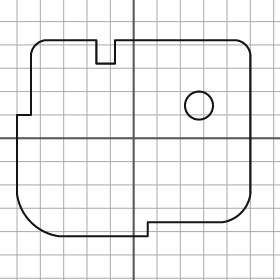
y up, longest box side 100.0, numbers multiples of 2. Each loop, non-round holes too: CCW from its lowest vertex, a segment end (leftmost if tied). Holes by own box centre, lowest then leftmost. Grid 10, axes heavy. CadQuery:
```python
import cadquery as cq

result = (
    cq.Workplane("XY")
    .moveTo(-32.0, -42.0)
    .lineTo(6.0, -42.0)
    .lineTo(6.0, -36.0)
    .lineTo(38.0, -36.0)
    .threePointArc((46.0, -32.0), (50.0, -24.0))
    .lineTo(50.0, 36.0)
    .threePointArc((48.0, 40.0), (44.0, 42.0))
    .lineTo(-8.0, 42.0)
    .lineTo(-8.0, 32.0)
    .lineTo(-16.0, 32.0)
    .lineTo(-16.0, 42.0)
    .lineTo(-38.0, 42.0)
    .threePointArc((-42.0, 40.0), (-44.0, 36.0))
    .lineTo(-44.0, 10.0)
    .lineTo(-50.0, 10.0)
    .lineTo(-50.0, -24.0)
    .threePointArc((-44.0, -36.0), (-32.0, -42.0))
    .close()
    .moveTo(28.0, 14.0)
    .circle(6.0)
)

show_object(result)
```